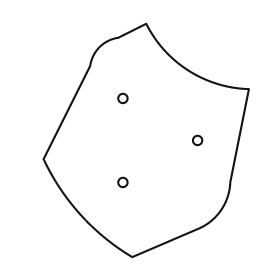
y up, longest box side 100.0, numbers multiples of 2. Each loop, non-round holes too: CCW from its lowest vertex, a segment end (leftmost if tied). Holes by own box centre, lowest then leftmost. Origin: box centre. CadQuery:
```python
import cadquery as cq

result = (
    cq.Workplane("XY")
    .moveTo(-6.0, -50.0)
    .lineTo(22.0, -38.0)
    .threePointArc((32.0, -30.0), (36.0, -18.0))
    .lineTo(44.0, 22.0)
    .threePointArc((18.0, 30.0), (0.0, 50.0))
    .lineTo(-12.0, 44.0)
    .threePointArc((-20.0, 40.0), (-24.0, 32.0))
    .lineTo(-44.0, -8.0)
    .threePointArc((-28.0, -32.0), (-6.0, -50.0))
    .close()
    .moveTo(-10.0, -18.0)
    .circle(2.0)
    .moveTo(22.0, 0.0)
    .circle(2.0)
    .moveTo(-10.0, 18.0)
    .circle(2.0)
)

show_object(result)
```